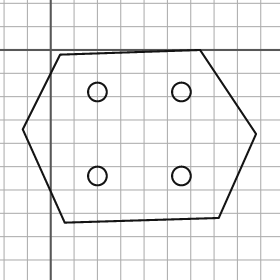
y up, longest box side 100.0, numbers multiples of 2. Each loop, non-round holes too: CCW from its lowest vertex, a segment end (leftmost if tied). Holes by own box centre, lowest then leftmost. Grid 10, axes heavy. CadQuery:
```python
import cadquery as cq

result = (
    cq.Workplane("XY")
    .moveTo(6.0, -74.0)
    .lineTo(72.0, -72.0)
    .lineTo(88.0, -36.0)
    .lineTo(64.0, 0.0)
    .lineTo(4.0, -2.0)
    .lineTo(-12.0, -34.0)
    .close()
    .moveTo(20.0, -54.0)
    .circle(4.0)
    .moveTo(56.0, -54.0)
    .circle(4.0)
    .moveTo(20.0, -18.0)
    .circle(4.0)
    .moveTo(56.0, -18.0)
    .circle(4.0)
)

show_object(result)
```